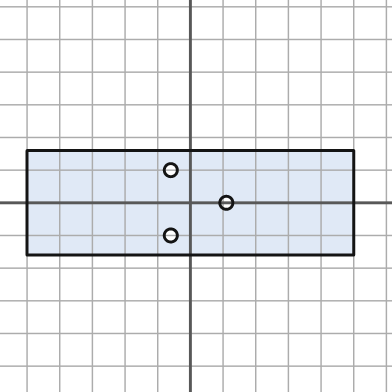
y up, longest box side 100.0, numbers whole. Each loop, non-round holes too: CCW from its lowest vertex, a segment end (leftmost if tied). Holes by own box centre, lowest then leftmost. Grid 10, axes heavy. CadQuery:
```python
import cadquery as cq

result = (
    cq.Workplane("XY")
    .moveTo(-50.0, -16.0)
    .lineTo(50.0, -16.0)
    .lineTo(50.0, 16.0)
    .lineTo(-50.0, 16.0)
    .close()
    .moveTo(-6.0, -10.0)
    .circle(2.0)
    .moveTo(11.0, 0.0)
    .circle(2.0)
    .moveTo(-6.0, 10.0)
    .circle(2.0)
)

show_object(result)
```